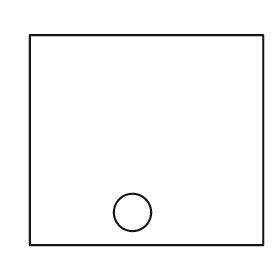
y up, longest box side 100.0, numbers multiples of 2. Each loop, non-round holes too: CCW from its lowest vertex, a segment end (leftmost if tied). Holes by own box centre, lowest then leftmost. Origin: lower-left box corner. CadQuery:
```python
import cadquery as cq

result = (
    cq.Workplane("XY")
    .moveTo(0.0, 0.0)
    .lineTo(100.0, 0.0)
    .lineTo(100.0, 90.0)
    .lineTo(0.0, 90.0)
    .close()
    .moveTo(44.0, 14.0)
    .circle(8.0)
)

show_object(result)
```